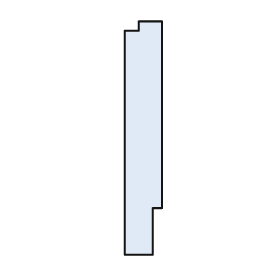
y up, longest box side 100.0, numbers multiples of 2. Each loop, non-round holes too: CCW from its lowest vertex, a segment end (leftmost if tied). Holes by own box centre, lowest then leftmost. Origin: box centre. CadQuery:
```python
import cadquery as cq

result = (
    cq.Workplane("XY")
    .moveTo(-8.0, -50.0)
    .lineTo(4.0, -50.0)
    .lineTo(4.0, -30.0)
    .lineTo(8.0, -30.0)
    .lineTo(8.0, 50.0)
    .lineTo(-2.0, 50.0)
    .lineTo(-2.0, 46.0)
    .lineTo(-8.0, 46.0)
    .close()
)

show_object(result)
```